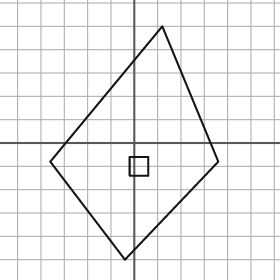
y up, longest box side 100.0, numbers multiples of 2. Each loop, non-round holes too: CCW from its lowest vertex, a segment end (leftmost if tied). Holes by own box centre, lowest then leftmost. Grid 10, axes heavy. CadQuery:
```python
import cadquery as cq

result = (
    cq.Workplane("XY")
    .moveTo(-4.0, -50.0)
    .lineTo(36.0, -8.0)
    .lineTo(12.0, 50.0)
    .lineTo(-36.0, -8.0)
    .close()
    .moveTo(-2.0, -14.0)
    .lineTo(6.0, -14.0)
    .lineTo(6.0, -6.0)
    .lineTo(-2.0, -6.0)
    .close()
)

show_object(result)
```